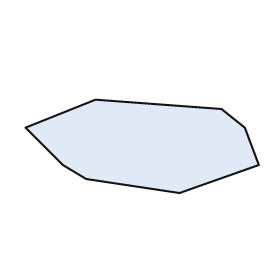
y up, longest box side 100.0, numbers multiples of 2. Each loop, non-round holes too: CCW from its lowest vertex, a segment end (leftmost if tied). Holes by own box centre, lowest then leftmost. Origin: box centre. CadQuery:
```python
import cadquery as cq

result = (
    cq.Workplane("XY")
    .moveTo(16.0, -20.0)
    .lineTo(50.0, -8.0)
    .lineTo(44.0, 8.0)
    .lineTo(34.0, 16.0)
    .lineTo(-20.0, 20.0)
    .lineTo(-50.0, 8.0)
    .lineTo(-34.0, -8.0)
    .lineTo(-24.0, -14.0)
    .close()
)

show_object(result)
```